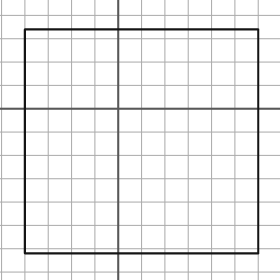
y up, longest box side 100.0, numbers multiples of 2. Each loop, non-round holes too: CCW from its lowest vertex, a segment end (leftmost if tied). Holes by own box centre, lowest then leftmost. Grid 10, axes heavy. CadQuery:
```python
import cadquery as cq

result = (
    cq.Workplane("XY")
    .moveTo(-40.0, -62.0)
    .lineTo(60.0, -62.0)
    .lineTo(60.0, 34.0)
    .lineTo(-40.0, 34.0)
    .close()
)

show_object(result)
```